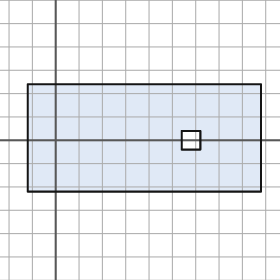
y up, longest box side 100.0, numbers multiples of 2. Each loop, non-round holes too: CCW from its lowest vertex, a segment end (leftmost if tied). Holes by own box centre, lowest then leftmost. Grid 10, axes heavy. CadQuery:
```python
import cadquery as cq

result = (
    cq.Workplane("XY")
    .moveTo(-12.0, -22.0)
    .lineTo(88.0, -22.0)
    .lineTo(88.0, 24.0)
    .lineTo(-12.0, 24.0)
    .close()
    .moveTo(54.0, -4.0)
    .lineTo(62.0, -4.0)
    .lineTo(62.0, 4.0)
    .lineTo(54.0, 4.0)
    .close()
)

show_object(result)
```